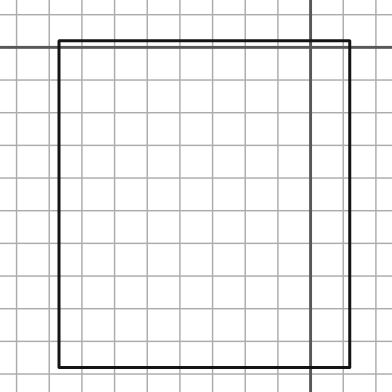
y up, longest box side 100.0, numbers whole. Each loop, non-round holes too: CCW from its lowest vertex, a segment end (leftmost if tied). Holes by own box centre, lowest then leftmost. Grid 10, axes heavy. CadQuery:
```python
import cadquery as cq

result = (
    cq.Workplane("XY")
    .moveTo(-77.0, -98.0)
    .lineTo(12.0, -98.0)
    .lineTo(12.0, 2.0)
    .lineTo(-77.0, 2.0)
    .close()
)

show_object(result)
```